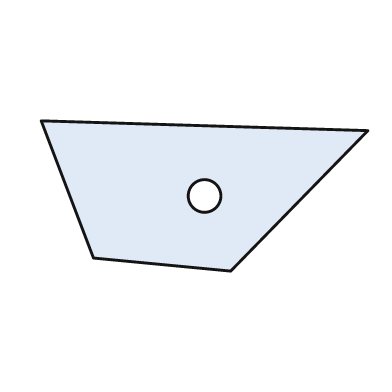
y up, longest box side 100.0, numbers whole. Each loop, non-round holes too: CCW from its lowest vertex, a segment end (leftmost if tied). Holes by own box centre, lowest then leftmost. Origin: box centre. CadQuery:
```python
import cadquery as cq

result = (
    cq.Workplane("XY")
    .moveTo(8.0, -23.0)
    .lineTo(50.0, 20.0)
    .lineTo(-50.0, 23.0)
    .lineTo(-34.0, -19.0)
    .close()
    .moveTo(0.0, 0.0)
    .circle(5.0)
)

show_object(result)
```